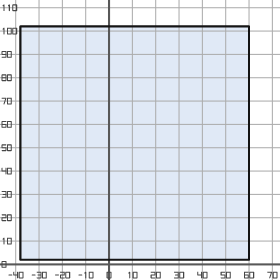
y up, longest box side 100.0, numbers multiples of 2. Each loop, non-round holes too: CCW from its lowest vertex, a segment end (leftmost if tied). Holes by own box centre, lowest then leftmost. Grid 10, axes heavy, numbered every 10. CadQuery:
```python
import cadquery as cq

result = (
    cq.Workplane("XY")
    .moveTo(-38.0, 2.0)
    .lineTo(60.0, 2.0)
    .lineTo(60.0, 102.0)
    .lineTo(-38.0, 102.0)
    .close()
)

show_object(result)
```